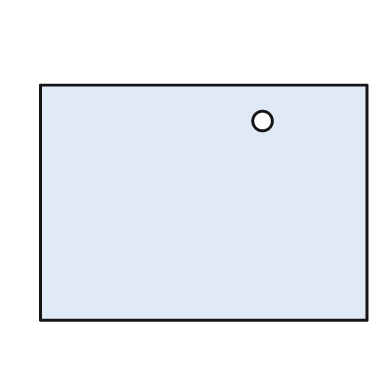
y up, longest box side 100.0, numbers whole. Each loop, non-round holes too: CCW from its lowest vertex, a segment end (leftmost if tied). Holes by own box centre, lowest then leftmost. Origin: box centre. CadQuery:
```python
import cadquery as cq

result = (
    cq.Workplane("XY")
    .moveTo(-50.0, -36.0)
    .lineTo(50.0, -36.0)
    .lineTo(50.0, 36.0)
    .lineTo(-50.0, 36.0)
    .close()
    .moveTo(18.0, 25.0)
    .circle(3.0)
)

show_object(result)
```